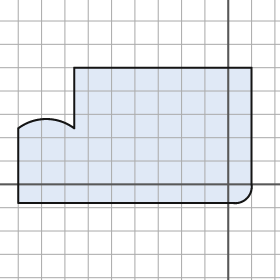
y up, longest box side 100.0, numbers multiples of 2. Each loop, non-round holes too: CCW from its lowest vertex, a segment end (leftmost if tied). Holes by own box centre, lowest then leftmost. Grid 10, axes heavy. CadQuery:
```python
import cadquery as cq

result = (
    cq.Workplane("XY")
    .moveTo(-90.0, -8.0)
    .lineTo(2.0, -8.0)
    .threePointArc((8.0, -6.0), (10.0, 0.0))
    .lineTo(10.0, 50.0)
    .lineTo(-66.0, 50.0)
    .lineTo(-66.0, 24.0)
    .threePointArc((-78.0, 28.0), (-90.0, 24.0))
    .close()
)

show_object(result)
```